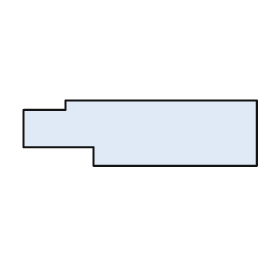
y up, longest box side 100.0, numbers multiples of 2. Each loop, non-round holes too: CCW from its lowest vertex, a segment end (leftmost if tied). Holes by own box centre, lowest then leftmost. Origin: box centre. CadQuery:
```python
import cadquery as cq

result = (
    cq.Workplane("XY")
    .moveTo(-20.0, -14.0)
    .lineTo(50.0, -14.0)
    .lineTo(50.0, 14.0)
    .lineTo(-32.0, 14.0)
    .lineTo(-32.0, 10.0)
    .lineTo(-50.0, 10.0)
    .lineTo(-50.0, -6.0)
    .lineTo(-20.0, -6.0)
    .close()
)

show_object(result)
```